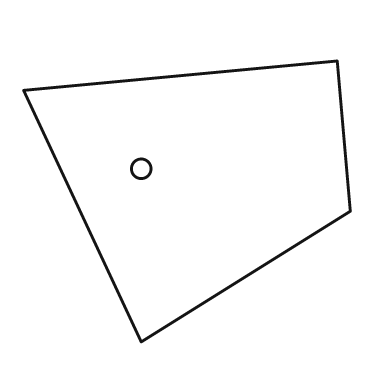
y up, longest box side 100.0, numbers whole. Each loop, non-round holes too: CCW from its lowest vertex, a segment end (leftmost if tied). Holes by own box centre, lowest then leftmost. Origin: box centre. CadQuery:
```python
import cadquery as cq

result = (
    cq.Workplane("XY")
    .moveTo(-14.0, -43.0)
    .lineTo(50.0, -3.0)
    .lineTo(46.0, 43.0)
    .lineTo(-50.0, 34.0)
    .close()
    .moveTo(-14.0, 10.0)
    .circle(3.0)
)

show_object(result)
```